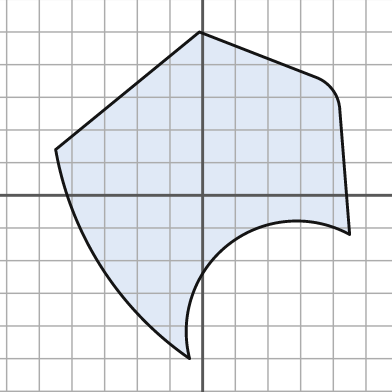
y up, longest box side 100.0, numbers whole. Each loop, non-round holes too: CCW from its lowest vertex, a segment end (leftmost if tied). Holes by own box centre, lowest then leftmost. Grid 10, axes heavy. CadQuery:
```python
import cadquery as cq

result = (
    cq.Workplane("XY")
    .moveTo(-4.0, -50.0)
    .threePointArc((8.0, -15.0), (45.0, -12.0))
    .lineTo(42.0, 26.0)
    .threePointArc((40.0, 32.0), (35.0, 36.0))
    .lineTo(-1.0, 50.0)
    .lineTo(-45.0, 14.0)
    .threePointArc((-31.0, -22.0), (-4.0, -50.0))
    .close()
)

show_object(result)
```